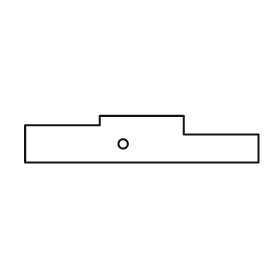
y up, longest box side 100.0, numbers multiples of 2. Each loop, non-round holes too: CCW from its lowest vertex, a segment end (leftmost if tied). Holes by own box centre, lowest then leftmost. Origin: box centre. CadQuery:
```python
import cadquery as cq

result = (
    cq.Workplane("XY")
    .moveTo(-50.0, -10.0)
    .lineTo(50.0, -10.0)
    .lineTo(50.0, 2.0)
    .lineTo(18.0, 2.0)
    .lineTo(18.0, 10.0)
    .lineTo(-18.0, 10.0)
    .lineTo(-18.0, 6.0)
    .lineTo(-50.0, 6.0)
    .close()
    .moveTo(-8.0, -2.0)
    .circle(2.0)
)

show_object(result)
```